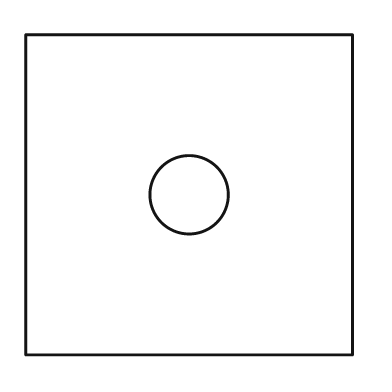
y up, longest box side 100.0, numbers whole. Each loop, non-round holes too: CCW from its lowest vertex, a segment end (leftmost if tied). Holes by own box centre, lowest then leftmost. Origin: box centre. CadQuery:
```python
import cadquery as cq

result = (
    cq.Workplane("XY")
    .moveTo(-50.0, -49.0)
    .lineTo(50.0, -49.0)
    .lineTo(50.0, 49.0)
    .lineTo(-50.0, 49.0)
    .close()
    .moveTo(0.0, 0.0)
    .circle(12.0)
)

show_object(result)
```